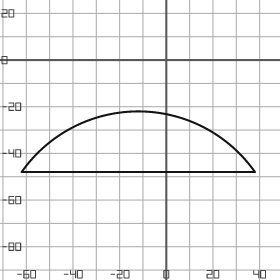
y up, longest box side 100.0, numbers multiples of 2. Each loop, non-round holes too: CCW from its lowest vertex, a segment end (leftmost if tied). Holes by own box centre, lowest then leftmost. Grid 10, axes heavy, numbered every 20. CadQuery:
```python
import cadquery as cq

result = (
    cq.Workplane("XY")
    .moveTo(-62.0, -48.0)
    .lineTo(38.0, -48.0)
    .threePointArc((-12.0, -22.0), (-62.0, -48.0))
    .close()
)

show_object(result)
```